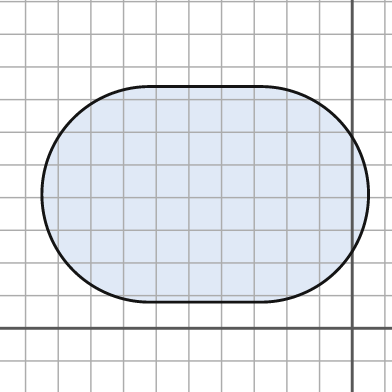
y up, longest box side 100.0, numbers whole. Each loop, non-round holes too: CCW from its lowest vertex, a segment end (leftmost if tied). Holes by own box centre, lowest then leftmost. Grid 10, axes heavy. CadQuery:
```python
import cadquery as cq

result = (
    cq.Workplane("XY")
    .moveTo(-62.0, 8.0)
    .lineTo(-28.0, 8.0)
    .threePointArc((5.0, 41.0), (-28.0, 74.0))
    .lineTo(-62.0, 74.0)
    .threePointArc((-95.0, 41.0), (-62.0, 8.0))
    .close()
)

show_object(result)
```